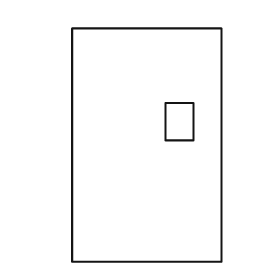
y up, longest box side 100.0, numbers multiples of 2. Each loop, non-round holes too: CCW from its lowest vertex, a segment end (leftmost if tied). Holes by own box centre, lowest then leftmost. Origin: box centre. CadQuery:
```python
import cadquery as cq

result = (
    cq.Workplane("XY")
    .moveTo(-32.0, -50.0)
    .lineTo(32.0, -50.0)
    .lineTo(32.0, 50.0)
    .lineTo(-32.0, 50.0)
    .close()
    .moveTo(8.0, 2.0)
    .lineTo(20.0, 2.0)
    .lineTo(20.0, 18.0)
    .lineTo(8.0, 18.0)
    .close()
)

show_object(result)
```